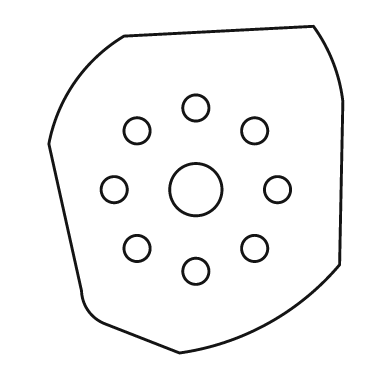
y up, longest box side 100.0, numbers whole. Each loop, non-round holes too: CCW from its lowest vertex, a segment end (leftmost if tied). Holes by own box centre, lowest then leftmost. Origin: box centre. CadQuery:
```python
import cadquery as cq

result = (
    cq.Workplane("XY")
    .moveTo(-5.0, -50.0)
    .threePointArc((22.0, -41.0), (44.0, -23.0))
    .lineTo(45.0, 27.0)
    .threePointArc((42.0, 39.0), (36.0, 50.0))
    .lineTo(-22.0, 47.0)
    .threePointArc((-37.0, 33.0), (-45.0, 14.0))
    .lineTo(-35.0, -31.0)
    .threePointArc((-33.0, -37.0), (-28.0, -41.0))
    .close()
    .moveTo(0.0, -25.0)
    .circle(4.0)
    .moveTo(-18.0, -18.0)
    .circle(4.0)
    .moveTo(18.0, -18.0)
    .circle(4.0)
    .moveTo(-25.0, 0.0)
    .circle(4.0)
    .moveTo(0.0, 0.0)
    .circle(8.0)
    .moveTo(25.0, 0.0)
    .circle(4.0)
    .moveTo(-18.0, 18.0)
    .circle(4.0)
    .moveTo(18.0, 18.0)
    .circle(4.0)
    .moveTo(0.0, 25.0)
    .circle(4.0)
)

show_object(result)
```